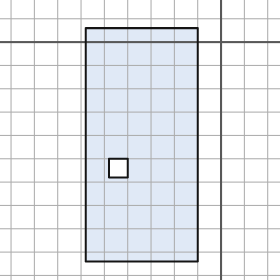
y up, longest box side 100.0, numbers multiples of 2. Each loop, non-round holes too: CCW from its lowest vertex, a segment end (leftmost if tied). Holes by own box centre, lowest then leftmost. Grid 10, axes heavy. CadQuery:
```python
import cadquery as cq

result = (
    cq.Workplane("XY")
    .moveTo(-58.0, -94.0)
    .lineTo(-10.0, -94.0)
    .lineTo(-10.0, 6.0)
    .lineTo(-58.0, 6.0)
    .close()
    .moveTo(-48.0, -58.0)
    .lineTo(-40.0, -58.0)
    .lineTo(-40.0, -50.0)
    .lineTo(-48.0, -50.0)
    .close()
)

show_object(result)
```